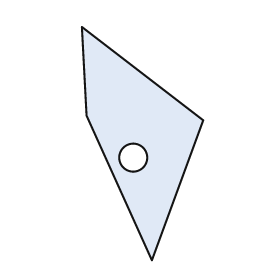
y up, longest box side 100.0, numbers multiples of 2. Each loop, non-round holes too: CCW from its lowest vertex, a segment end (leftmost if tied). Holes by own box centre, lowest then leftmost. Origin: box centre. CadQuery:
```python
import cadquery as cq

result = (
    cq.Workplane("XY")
    .moveTo(4.0, -50.0)
    .lineTo(26.0, 10.0)
    .lineTo(-26.0, 50.0)
    .lineTo(-24.0, 12.0)
    .close()
    .moveTo(-4.0, -6.0)
    .circle(6.0)
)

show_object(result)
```